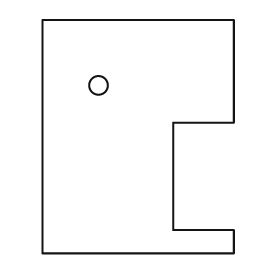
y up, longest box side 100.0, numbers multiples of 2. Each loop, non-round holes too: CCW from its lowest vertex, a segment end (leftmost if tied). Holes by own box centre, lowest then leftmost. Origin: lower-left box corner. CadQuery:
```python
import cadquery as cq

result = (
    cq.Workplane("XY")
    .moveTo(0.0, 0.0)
    .lineTo(82.0, 0.0)
    .lineTo(82.0, 10.0)
    .lineTo(56.0, 10.0)
    .lineTo(56.0, 56.0)
    .lineTo(82.0, 56.0)
    .lineTo(82.0, 100.0)
    .lineTo(0.0, 100.0)
    .close()
    .moveTo(24.0, 72.0)
    .circle(4.0)
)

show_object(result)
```